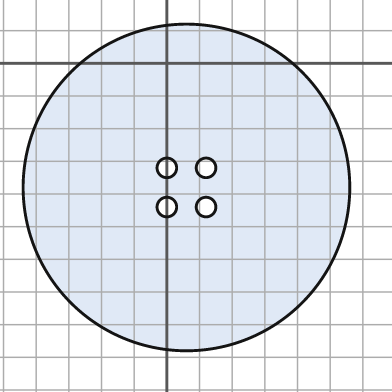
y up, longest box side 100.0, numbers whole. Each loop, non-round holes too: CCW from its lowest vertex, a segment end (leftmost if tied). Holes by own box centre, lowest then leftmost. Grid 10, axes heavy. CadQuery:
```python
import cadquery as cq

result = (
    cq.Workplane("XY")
    .moveTo(6.0, -38.0)
    .circle(50.0)
    .moveTo(0.0, -44.0)
    .circle(3.0)
    .moveTo(12.0, -44.0)
    .circle(3.0)
    .moveTo(0.0, -32.0)
    .circle(3.0)
    .moveTo(12.0, -32.0)
    .circle(3.0)
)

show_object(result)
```